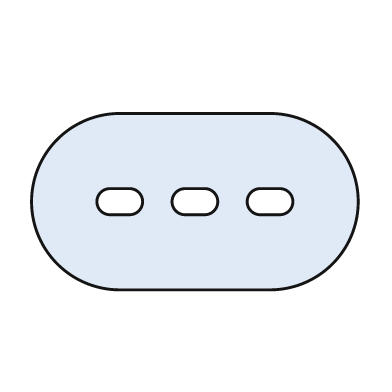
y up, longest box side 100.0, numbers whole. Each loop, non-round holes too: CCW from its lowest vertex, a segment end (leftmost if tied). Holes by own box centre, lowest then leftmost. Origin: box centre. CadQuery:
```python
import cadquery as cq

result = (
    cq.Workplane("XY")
    .moveTo(-23.0, -27.0)
    .lineTo(23.0, -27.0)
    .threePointArc((50.0, 0.0), (23.0, 27.0))
    .lineTo(-23.0, 27.0)
    .threePointArc((-50.0, 0.0), (-23.0, -27.0))
    .close()
    .moveTo(-26.0, -4.0)
    .lineTo(-20.0, -4.0)
    .threePointArc((-16.0, 0.0), (-20.0, 4.0))
    .lineTo(-26.0, 4.0)
    .threePointArc((-30.0, 0.0), (-26.0, -4.0))
    .close()
    .moveTo(-3.0, -4.0)
    .lineTo(3.0, -4.0)
    .threePointArc((7.0, 0.0), (3.0, 4.0))
    .lineTo(-3.0, 4.0)
    .threePointArc((-7.0, 0.0), (-3.0, -4.0))
    .close()
    .moveTo(20.0, -4.0)
    .lineTo(26.0, -4.0)
    .threePointArc((30.0, 0.0), (26.0, 4.0))
    .lineTo(20.0, 4.0)
    .threePointArc((16.0, 0.0), (20.0, -4.0))
    .close()
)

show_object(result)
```